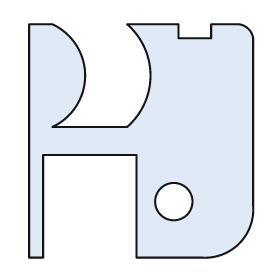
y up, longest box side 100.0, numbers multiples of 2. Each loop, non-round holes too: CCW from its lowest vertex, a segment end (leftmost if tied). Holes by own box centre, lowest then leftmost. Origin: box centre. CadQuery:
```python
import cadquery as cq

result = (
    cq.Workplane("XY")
    .moveTo(-48.0, -50.0)
    .lineTo(-42.0, -50.0)
    .lineTo(-42.0, -6.0)
    .lineTo(-2.0, -6.0)
    .lineTo(-2.0, -50.0)
    .lineTo(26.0, -50.0)
    .threePointArc((42.0, -44.0), (48.0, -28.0))
    .lineTo(48.0, 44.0)
    .threePointArc((46.0, 48.0), (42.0, 50.0))
    .lineTo(30.0, 50.0)
    .lineTo(30.0, 44.0)
    .lineTo(16.0, 44.0)
    .lineTo(16.0, 50.0)
    .lineTo(-6.0, 50.0)
    .threePointArc((4.0, 28.0), (-6.0, 6.0))
    .lineTo(-38.0, 6.0)
    .threePointArc((-24.0, 28.0), (-38.0, 50.0))
    .lineTo(-48.0, 50.0)
    .close()
    .moveTo(14.0, -26.0)
    .circle(8.0)
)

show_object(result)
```